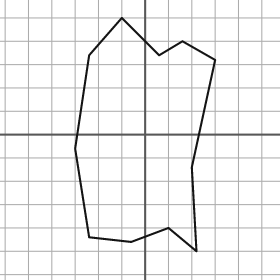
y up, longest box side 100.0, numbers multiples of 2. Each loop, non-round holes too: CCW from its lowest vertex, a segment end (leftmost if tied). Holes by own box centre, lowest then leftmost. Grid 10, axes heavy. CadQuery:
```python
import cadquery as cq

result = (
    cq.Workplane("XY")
    .moveTo(22.0, -50.0)
    .lineTo(20.0, -14.0)
    .lineTo(30.0, 32.0)
    .lineTo(16.0, 40.0)
    .lineTo(6.0, 34.0)
    .lineTo(-10.0, 50.0)
    .lineTo(-24.0, 34.0)
    .lineTo(-30.0, -6.0)
    .lineTo(-24.0, -44.0)
    .lineTo(-6.0, -46.0)
    .lineTo(10.0, -40.0)
    .close()
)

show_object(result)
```